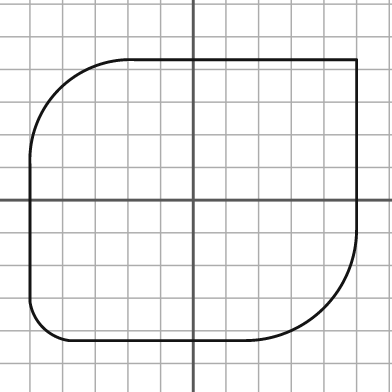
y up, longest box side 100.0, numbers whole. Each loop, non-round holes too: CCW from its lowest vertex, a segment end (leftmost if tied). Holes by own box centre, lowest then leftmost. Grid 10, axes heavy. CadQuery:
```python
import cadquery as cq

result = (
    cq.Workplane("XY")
    .moveTo(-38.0, -43.0)
    .lineTo(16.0, -43.0)
    .threePointArc((40.0, -33.0), (50.0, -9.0))
    .lineTo(50.0, 43.0)
    .lineTo(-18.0, 43.0)
    .threePointArc((-41.0, 34.0), (-50.0, 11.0))
    .lineTo(-50.0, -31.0)
    .threePointArc((-46.0, -39.0), (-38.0, -43.0))
    .close()
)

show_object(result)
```